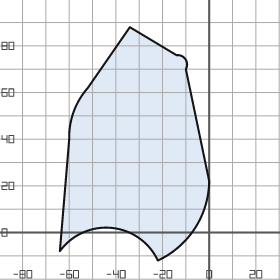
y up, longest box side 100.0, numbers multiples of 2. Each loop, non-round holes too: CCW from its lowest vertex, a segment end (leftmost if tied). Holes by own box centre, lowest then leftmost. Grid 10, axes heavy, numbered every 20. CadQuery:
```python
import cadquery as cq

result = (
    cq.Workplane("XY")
    .moveTo(-22.0, -12.0)
    .threePointArc((-6.0, 2.0), (0.0, 22.0))
    .lineTo(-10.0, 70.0)
    .threePointArc((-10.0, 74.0), (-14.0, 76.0))
    .lineTo(-34.0, 88.0)
    .lineTo(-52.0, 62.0)
    .threePointArc((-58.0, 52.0), (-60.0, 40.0))
    .lineTo(-64.0, -8.0)
    .threePointArc((-42.0, 2.0), (-22.0, -12.0))
    .close()
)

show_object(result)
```